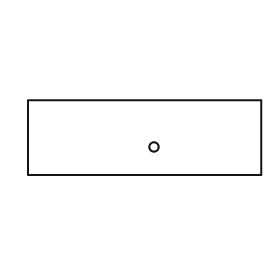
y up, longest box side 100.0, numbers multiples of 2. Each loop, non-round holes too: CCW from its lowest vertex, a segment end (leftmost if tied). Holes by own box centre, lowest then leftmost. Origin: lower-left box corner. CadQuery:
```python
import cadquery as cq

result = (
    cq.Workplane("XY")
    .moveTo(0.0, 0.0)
    .lineTo(100.0, 0.0)
    .lineTo(100.0, 32.0)
    .lineTo(0.0, 32.0)
    .close()
    .moveTo(54.0, 12.0)
    .circle(2.0)
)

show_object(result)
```